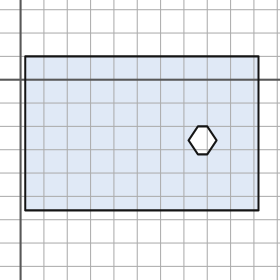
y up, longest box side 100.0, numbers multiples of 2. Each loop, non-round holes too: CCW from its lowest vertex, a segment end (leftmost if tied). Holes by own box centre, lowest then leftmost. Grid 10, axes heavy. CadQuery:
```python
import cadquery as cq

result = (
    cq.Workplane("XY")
    .moveTo(2.0, -56.0)
    .lineTo(102.0, -56.0)
    .lineTo(102.0, 10.0)
    .lineTo(2.0, 10.0)
    .close()
    .moveTo(76.0, -32.0)
    .lineTo(80.0, -32.0)
    .lineTo(84.0, -26.0)
    .lineTo(80.0, -20.0)
    .lineTo(76.0, -20.0)
    .lineTo(72.0, -26.0)
    .close()
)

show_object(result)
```